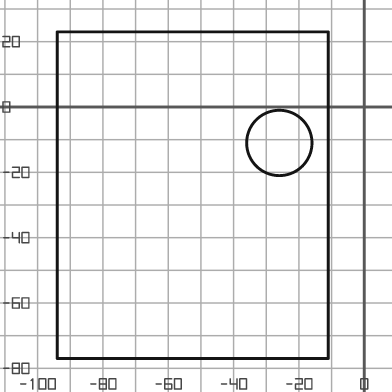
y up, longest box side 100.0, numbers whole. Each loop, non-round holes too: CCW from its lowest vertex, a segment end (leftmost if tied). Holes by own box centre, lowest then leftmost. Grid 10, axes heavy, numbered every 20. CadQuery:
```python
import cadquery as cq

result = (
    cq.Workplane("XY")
    .moveTo(-94.0, -77.0)
    .lineTo(-11.0, -77.0)
    .lineTo(-11.0, 23.0)
    .lineTo(-94.0, 23.0)
    .close()
    .moveTo(-26.0, -11.0)
    .circle(10.0)
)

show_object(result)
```